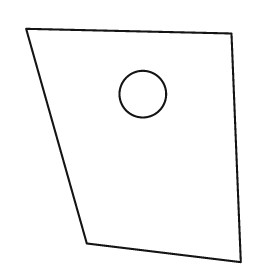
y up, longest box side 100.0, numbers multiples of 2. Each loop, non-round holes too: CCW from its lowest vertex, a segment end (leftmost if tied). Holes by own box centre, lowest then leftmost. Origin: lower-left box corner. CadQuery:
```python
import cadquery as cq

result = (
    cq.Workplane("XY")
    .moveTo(92.0, 0.0)
    .lineTo(88.0, 98.0)
    .lineTo(0.0, 100.0)
    .lineTo(26.0, 8.0)
    .close()
    .moveTo(50.0, 72.0)
    .circle(10.0)
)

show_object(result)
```